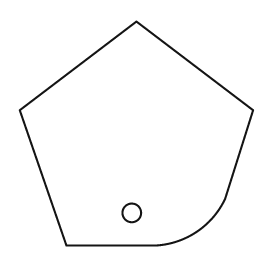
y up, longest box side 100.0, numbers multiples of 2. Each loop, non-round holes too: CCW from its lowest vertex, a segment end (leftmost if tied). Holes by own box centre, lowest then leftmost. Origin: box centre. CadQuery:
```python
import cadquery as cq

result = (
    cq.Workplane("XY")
    .moveTo(-30.0, -48.0)
    .lineTo(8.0, -48.0)
    .threePointArc((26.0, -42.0), (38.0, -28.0))
    .lineTo(50.0, 10.0)
    .lineTo(0.0, 48.0)
    .lineTo(-50.0, 10.0)
    .close()
    .moveTo(-2.0, -34.0)
    .circle(4.0)
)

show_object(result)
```